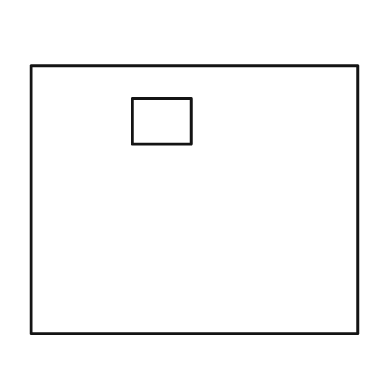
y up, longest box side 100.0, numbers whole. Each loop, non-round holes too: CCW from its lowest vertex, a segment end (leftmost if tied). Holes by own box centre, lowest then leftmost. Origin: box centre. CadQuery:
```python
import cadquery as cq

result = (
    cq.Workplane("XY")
    .moveTo(-50.0, -41.0)
    .lineTo(50.0, -41.0)
    .lineTo(50.0, 41.0)
    .lineTo(-50.0, 41.0)
    .close()
    .moveTo(-19.0, 17.0)
    .lineTo(-1.0, 17.0)
    .lineTo(-1.0, 31.0)
    .lineTo(-19.0, 31.0)
    .close()
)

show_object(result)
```